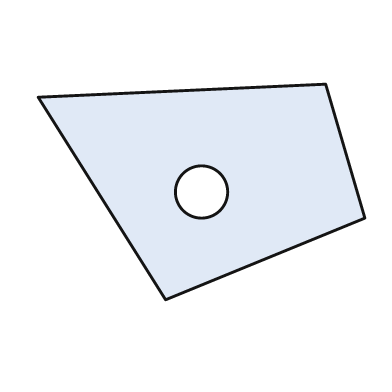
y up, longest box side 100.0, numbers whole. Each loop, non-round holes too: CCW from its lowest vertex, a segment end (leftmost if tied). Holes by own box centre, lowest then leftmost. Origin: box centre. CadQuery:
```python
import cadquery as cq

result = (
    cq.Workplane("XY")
    .moveTo(-11.0, -33.0)
    .lineTo(50.0, -8.0)
    .lineTo(38.0, 33.0)
    .lineTo(-50.0, 29.0)
    .close()
    .moveTo(0.0, 0.0)
    .circle(8.0)
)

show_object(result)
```